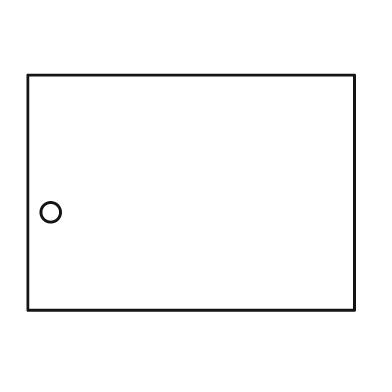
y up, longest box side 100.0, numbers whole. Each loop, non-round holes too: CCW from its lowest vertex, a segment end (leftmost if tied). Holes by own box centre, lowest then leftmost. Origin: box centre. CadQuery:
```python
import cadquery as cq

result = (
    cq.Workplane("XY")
    .moveTo(-50.0, -36.0)
    .lineTo(50.0, -36.0)
    .lineTo(50.0, 36.0)
    .lineTo(-50.0, 36.0)
    .close()
    .moveTo(-43.0, -6.0)
    .circle(3.0)
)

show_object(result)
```